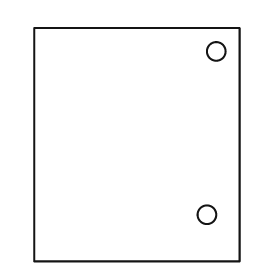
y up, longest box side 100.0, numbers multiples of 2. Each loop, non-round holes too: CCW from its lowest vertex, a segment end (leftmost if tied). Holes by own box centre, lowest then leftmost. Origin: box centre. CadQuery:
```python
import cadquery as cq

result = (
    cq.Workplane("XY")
    .moveTo(-44.0, -50.0)
    .lineTo(44.0, -50.0)
    .lineTo(44.0, 50.0)
    .lineTo(-44.0, 50.0)
    .close()
    .moveTo(30.0, -30.0)
    .circle(4.0)
    .moveTo(34.0, 40.0)
    .circle(4.0)
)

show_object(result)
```